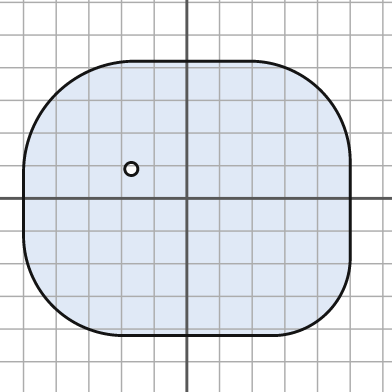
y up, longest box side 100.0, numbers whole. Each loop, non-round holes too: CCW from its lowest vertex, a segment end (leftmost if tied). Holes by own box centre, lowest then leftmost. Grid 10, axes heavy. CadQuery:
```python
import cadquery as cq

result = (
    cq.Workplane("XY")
    .moveTo(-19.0, -42.0)
    .lineTo(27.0, -42.0)
    .threePointArc((43.0, -35.0), (50.0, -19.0))
    .lineTo(50.0, 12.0)
    .threePointArc((41.0, 33.0), (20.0, 42.0))
    .lineTo(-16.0, 42.0)
    .threePointArc((-40.0, 32.0), (-50.0, 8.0))
    .lineTo(-50.0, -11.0)
    .threePointArc((-41.0, -33.0), (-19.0, -42.0))
    .close()
    .moveTo(-17.0, 9.0)
    .circle(2.0)
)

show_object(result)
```